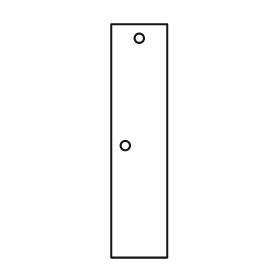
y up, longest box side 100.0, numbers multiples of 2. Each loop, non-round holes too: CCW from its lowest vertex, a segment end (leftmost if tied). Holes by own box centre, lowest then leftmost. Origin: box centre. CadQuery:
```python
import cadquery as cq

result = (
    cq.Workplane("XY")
    .moveTo(-12.0, -50.0)
    .lineTo(12.0, -50.0)
    .lineTo(12.0, 50.0)
    .lineTo(-12.0, 50.0)
    .close()
    .moveTo(-6.0, -2.0)
    .circle(2.0)
    .moveTo(0.0, 44.0)
    .circle(2.0)
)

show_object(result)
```